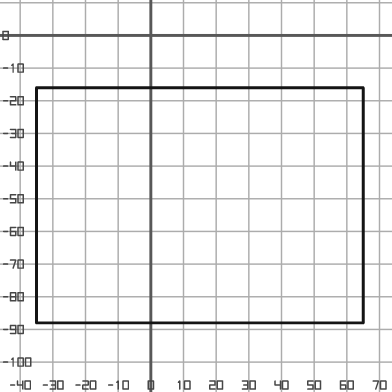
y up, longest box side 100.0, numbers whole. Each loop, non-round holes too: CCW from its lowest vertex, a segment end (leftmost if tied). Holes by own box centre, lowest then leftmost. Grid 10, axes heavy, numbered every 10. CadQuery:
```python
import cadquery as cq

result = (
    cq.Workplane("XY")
    .moveTo(-35.0, -88.0)
    .lineTo(65.0, -88.0)
    .lineTo(65.0, -16.0)
    .lineTo(-35.0, -16.0)
    .close()
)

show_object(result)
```